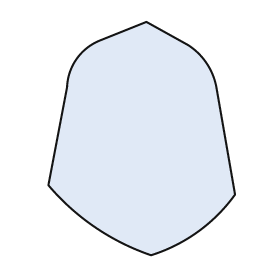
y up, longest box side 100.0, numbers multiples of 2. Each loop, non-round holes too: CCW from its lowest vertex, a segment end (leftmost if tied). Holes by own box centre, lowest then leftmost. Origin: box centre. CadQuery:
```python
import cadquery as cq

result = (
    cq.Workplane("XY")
    .moveTo(4.0, -50.0)
    .threePointArc((24.0, -40.0), (40.0, -24.0))
    .lineTo(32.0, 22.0)
    .threePointArc((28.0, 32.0), (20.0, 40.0))
    .lineTo(2.0, 50.0)
    .lineTo(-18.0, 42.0)
    .threePointArc((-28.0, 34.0), (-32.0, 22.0))
    .lineTo(-40.0, -20.0)
    .threePointArc((-20.0, -38.0), (4.0, -50.0))
    .close()
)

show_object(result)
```